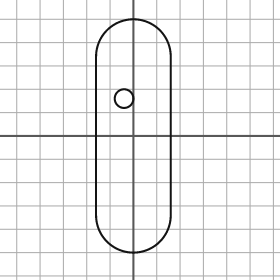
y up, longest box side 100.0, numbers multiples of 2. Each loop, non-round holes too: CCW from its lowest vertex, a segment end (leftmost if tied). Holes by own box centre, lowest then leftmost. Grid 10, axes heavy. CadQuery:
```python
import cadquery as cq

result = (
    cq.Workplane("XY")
    .moveTo(-16.0, -34.0)
    .threePointArc((0.0, -50.0), (16.0, -34.0))
    .lineTo(16.0, 34.0)
    .threePointArc((0.0, 50.0), (-16.0, 34.0))
    .close()
    .moveTo(-4.0, 16.0)
    .circle(4.0)
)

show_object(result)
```